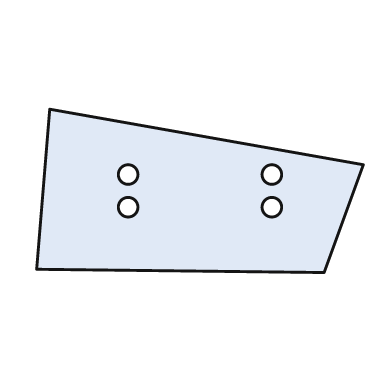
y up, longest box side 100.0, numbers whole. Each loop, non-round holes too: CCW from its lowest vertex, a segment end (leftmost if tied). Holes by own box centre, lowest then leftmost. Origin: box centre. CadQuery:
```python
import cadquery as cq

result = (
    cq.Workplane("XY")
    .moveTo(38.0, -25.0)
    .lineTo(50.0, 8.0)
    .lineTo(-46.0, 25.0)
    .lineTo(-50.0, -24.0)
    .close()
    .moveTo(-22.0, -5.0)
    .circle(3.0)
    .moveTo(22.0, -5.0)
    .circle(3.0)
    .moveTo(-22.0, 5.0)
    .circle(3.0)
    .moveTo(22.0, 5.0)
    .circle(3.0)
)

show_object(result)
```